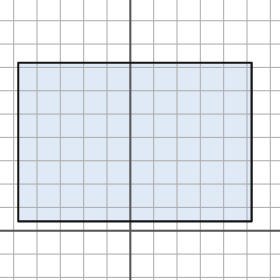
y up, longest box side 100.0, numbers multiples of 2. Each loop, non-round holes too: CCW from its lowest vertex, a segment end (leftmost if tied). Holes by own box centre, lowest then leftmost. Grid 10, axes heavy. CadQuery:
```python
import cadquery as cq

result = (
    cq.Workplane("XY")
    .moveTo(-48.0, 4.0)
    .lineTo(52.0, 4.0)
    .lineTo(52.0, 72.0)
    .lineTo(-48.0, 72.0)
    .close()
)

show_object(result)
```